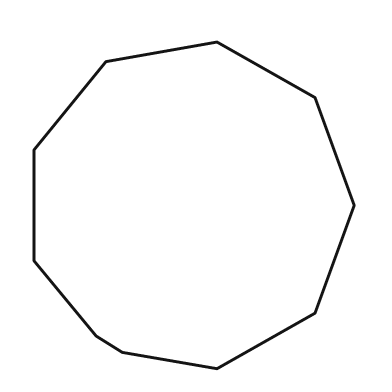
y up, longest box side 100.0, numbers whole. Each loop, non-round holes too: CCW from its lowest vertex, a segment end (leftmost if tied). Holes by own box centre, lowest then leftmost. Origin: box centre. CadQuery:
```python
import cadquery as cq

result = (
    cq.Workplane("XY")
    .moveTo(7.0, -50.0)
    .lineTo(37.0, -33.0)
    .lineTo(49.0, 0.0)
    .lineTo(37.0, 33.0)
    .lineTo(7.0, 50.0)
    .lineTo(-27.0, 44.0)
    .lineTo(-49.0, 17.0)
    .lineTo(-49.0, -17.0)
    .lineTo(-30.0, -40.0)
    .lineTo(-22.0, -45.0)
    .close()
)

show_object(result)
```